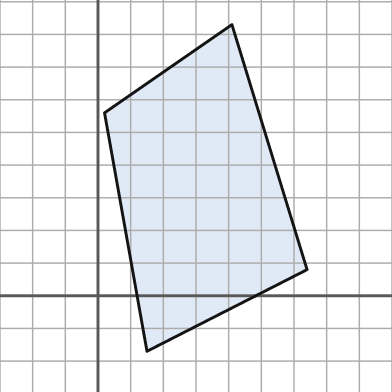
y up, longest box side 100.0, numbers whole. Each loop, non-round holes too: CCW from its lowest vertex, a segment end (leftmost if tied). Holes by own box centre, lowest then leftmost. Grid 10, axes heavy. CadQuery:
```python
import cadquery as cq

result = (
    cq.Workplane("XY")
    .moveTo(15.0, -17.0)
    .lineTo(64.0, 8.0)
    .lineTo(41.0, 83.0)
    .lineTo(2.0, 56.0)
    .close()
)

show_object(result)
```